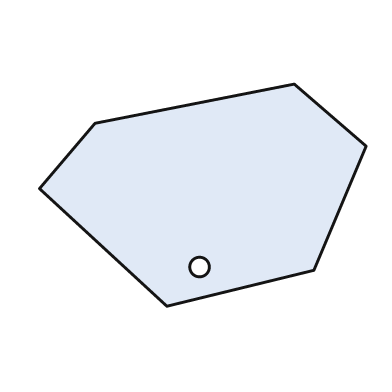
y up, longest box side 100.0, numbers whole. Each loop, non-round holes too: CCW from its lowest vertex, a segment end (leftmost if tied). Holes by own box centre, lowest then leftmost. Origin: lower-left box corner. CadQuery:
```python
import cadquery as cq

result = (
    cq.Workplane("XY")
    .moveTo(39.0, 0.0)
    .lineTo(84.0, 11.0)
    .lineTo(100.0, 49.0)
    .lineTo(78.0, 68.0)
    .lineTo(17.0, 56.0)
    .lineTo(0.0, 36.0)
    .close()
    .moveTo(49.0, 12.0)
    .circle(3.0)
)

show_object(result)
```